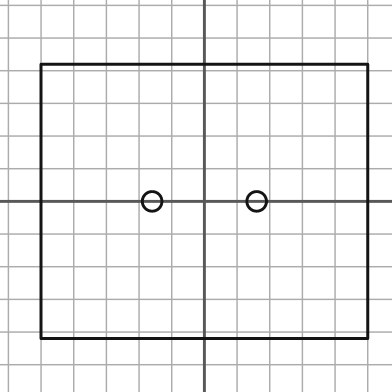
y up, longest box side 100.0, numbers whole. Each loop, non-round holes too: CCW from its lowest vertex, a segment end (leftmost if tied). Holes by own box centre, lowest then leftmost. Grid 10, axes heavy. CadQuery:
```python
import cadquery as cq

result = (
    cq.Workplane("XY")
    .moveTo(-50.0, -42.0)
    .lineTo(50.0, -42.0)
    .lineTo(50.0, 42.0)
    .lineTo(-50.0, 42.0)
    .close()
    .moveTo(-16.0, 0.0)
    .circle(3.0)
    .moveTo(16.0, 0.0)
    .circle(3.0)
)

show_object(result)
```